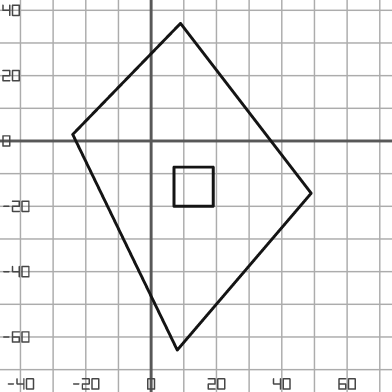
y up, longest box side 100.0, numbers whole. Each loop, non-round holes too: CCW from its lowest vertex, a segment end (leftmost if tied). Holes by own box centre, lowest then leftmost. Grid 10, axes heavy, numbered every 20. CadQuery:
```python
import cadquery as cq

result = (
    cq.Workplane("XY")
    .moveTo(8.0, -64.0)
    .lineTo(49.0, -16.0)
    .lineTo(9.0, 36.0)
    .lineTo(-24.0, 2.0)
    .close()
    .moveTo(7.0, -20.0)
    .lineTo(19.0, -20.0)
    .lineTo(19.0, -8.0)
    .lineTo(7.0, -8.0)
    .close()
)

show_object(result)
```